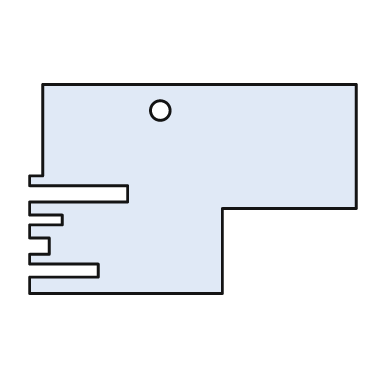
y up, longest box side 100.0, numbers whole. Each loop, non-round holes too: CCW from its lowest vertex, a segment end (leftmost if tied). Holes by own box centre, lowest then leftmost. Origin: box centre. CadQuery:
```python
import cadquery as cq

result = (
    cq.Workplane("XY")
    .moveTo(-50.0, -32.0)
    .lineTo(9.0, -32.0)
    .lineTo(9.0, -6.0)
    .lineTo(50.0, -6.0)
    .lineTo(50.0, 32.0)
    .lineTo(-46.0, 32.0)
    .lineTo(-46.0, 4.0)
    .lineTo(-50.0, 4.0)
    .lineTo(-50.0, 1.0)
    .lineTo(-20.0, 1.0)
    .lineTo(-20.0, -4.0)
    .lineTo(-50.0, -4.0)
    .lineTo(-50.0, -8.0)
    .lineTo(-40.0, -8.0)
    .lineTo(-40.0, -11.0)
    .lineTo(-50.0, -11.0)
    .lineTo(-50.0, -15.0)
    .lineTo(-44.0, -15.0)
    .lineTo(-44.0, -20.0)
    .lineTo(-50.0, -20.0)
    .lineTo(-50.0, -23.0)
    .lineTo(-29.0, -23.0)
    .lineTo(-29.0, -27.0)
    .lineTo(-50.0, -27.0)
    .close()
    .moveTo(-10.0, 24.0)
    .circle(3.0)
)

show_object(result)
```